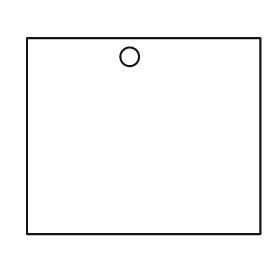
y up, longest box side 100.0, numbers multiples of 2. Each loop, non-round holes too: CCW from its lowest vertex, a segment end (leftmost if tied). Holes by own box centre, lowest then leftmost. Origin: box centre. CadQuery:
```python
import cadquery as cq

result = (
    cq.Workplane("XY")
    .moveTo(-50.0, -42.0)
    .lineTo(50.0, -42.0)
    .lineTo(50.0, 42.0)
    .lineTo(-50.0, 42.0)
    .close()
    .moveTo(-6.0, 34.0)
    .circle(4.0)
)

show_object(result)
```